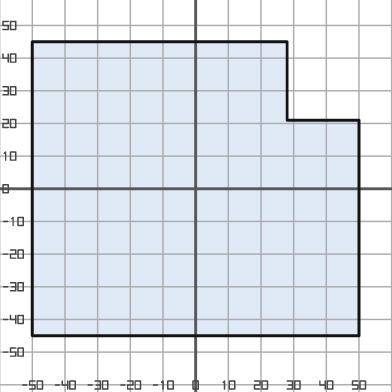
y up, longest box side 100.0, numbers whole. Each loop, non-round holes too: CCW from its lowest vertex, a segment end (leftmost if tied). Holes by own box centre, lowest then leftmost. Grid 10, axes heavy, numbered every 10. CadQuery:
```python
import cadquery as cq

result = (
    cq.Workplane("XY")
    .moveTo(-50.0, -45.0)
    .lineTo(50.0, -45.0)
    .lineTo(50.0, 21.0)
    .lineTo(28.0, 21.0)
    .lineTo(28.0, 45.0)
    .lineTo(-50.0, 45.0)
    .close()
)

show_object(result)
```